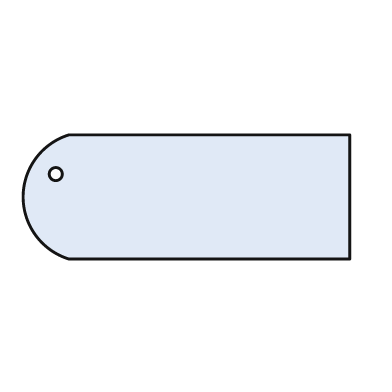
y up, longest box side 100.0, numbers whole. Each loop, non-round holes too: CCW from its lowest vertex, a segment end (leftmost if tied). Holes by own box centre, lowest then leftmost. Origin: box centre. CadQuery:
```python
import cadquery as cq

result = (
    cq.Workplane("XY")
    .moveTo(-36.0, -19.0)
    .lineTo(50.0, -19.0)
    .lineTo(50.0, 19.0)
    .lineTo(-36.0, 19.0)
    .threePointArc((-50.0, 0.0), (-36.0, -19.0))
    .close()
    .moveTo(-40.0, 7.0)
    .circle(2.0)
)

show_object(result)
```